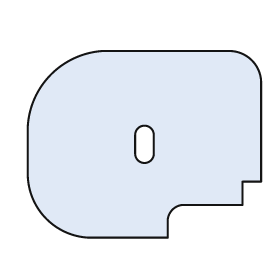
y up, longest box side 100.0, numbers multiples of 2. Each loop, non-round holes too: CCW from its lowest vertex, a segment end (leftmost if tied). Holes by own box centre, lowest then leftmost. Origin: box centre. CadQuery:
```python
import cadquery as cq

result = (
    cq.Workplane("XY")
    .moveTo(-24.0, -40.0)
    .lineTo(10.0, -40.0)
    .lineTo(10.0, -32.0)
    .threePointArc((12.0, -28.0), (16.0, -26.0))
    .lineTo(42.0, -26.0)
    .lineTo(42.0, -16.0)
    .lineTo(50.0, -16.0)
    .lineTo(50.0, 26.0)
    .threePointArc((46.0, 36.0), (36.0, 40.0))
    .lineTo(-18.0, 40.0)
    .threePointArc((-40.0, 30.0), (-50.0, 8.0))
    .lineTo(-50.0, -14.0)
    .threePointArc((-42.0, -32.0), (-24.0, -40.0))
    .close()
    .moveTo(-4.0, -4.0)
    .threePointArc((0.0, -8.0), (4.0, -4.0))
    .lineTo(4.0, 4.0)
    .threePointArc((0.0, 8.0), (-4.0, 4.0))
    .close()
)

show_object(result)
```